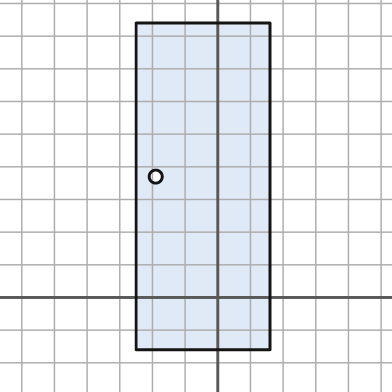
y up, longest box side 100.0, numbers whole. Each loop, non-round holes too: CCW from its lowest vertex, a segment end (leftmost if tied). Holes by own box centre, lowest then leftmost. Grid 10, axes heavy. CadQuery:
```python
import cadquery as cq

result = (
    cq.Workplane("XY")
    .moveTo(-25.0, -16.0)
    .lineTo(16.0, -16.0)
    .lineTo(16.0, 84.0)
    .lineTo(-25.0, 84.0)
    .close()
    .moveTo(-19.0, 37.0)
    .circle(2.0)
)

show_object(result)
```